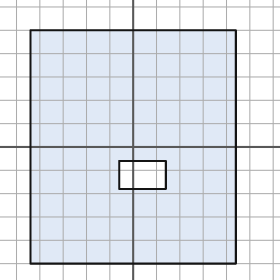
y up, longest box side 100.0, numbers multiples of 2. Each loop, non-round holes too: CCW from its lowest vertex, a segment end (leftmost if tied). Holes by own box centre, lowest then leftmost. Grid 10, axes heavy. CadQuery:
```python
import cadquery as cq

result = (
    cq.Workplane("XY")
    .moveTo(-44.0, -50.0)
    .lineTo(44.0, -50.0)
    .lineTo(44.0, 50.0)
    .lineTo(-44.0, 50.0)
    .close()
    .moveTo(-6.0, -18.0)
    .lineTo(14.0, -18.0)
    .lineTo(14.0, -6.0)
    .lineTo(-6.0, -6.0)
    .close()
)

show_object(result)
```